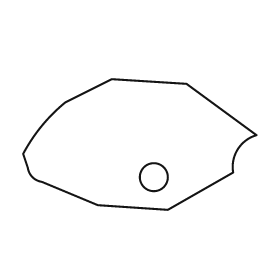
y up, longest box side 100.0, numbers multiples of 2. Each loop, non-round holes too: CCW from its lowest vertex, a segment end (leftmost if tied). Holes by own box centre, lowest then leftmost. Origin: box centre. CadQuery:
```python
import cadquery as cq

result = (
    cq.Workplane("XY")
    .moveTo(12.0, -28.0)
    .lineTo(40.0, -12.0)
    .threePointArc((42.0, -2.0), (50.0, 4.0))
    .lineTo(20.0, 26.0)
    .lineTo(-12.0, 28.0)
    .lineTo(-32.0, 18.0)
    .threePointArc((-42.0, 8.0), (-50.0, -4.0))
    .lineTo(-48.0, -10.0)
    .threePointArc((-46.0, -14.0), (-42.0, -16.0))
    .lineTo(-18.0, -26.0)
    .close()
    .moveTo(6.0, -14.0)
    .circle(6.0)
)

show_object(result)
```